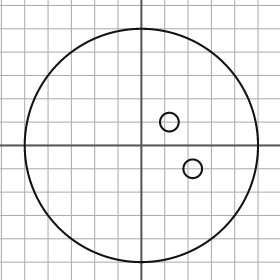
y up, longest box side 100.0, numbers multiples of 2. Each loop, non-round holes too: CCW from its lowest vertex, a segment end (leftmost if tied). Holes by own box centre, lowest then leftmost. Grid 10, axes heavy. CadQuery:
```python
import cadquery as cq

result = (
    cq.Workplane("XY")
    .moveTo(0.0, 0.0)
    .circle(50.0)
    .moveTo(22.0, -10.0)
    .circle(4.0)
    .moveTo(12.0, 10.0)
    .circle(4.0)
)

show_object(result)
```